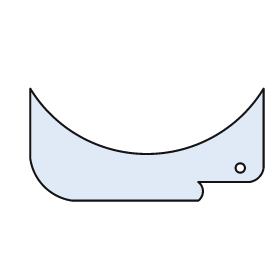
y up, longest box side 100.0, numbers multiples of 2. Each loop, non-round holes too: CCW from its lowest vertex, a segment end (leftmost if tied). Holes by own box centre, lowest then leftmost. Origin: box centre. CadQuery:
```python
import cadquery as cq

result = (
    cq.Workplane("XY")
    .moveTo(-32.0, -24.0)
    .lineTo(22.0, -24.0)
    .threePointArc((24.0, -20.0), (22.0, -16.0))
    .lineTo(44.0, -16.0)
    .threePointArc((48.0, -14.0), (50.0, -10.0))
    .lineTo(50.0, 24.0)
    .threePointArc((0.0, -4.0), (-50.0, 24.0))
    .lineTo(-50.0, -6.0)
    .threePointArc((-44.0, -18.0), (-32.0, -24.0))
    .close()
    .moveTo(40.0, -10.0)
    .circle(2.0)
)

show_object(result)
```